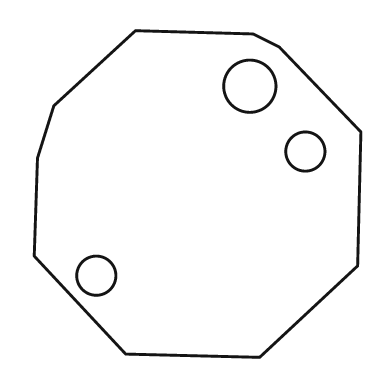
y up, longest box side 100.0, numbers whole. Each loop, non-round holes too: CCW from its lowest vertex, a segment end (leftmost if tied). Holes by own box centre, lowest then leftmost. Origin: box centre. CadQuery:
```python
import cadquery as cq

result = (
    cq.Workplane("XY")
    .moveTo(19.0, -50.0)
    .lineTo(49.0, -22.0)
    .lineTo(50.0, 19.0)
    .lineTo(25.0, 45.0)
    .lineTo(17.0, 49.0)
    .lineTo(-19.0, 50.0)
    .lineTo(-44.0, 27.0)
    .lineTo(-49.0, 11.0)
    .lineTo(-50.0, -19.0)
    .lineTo(-22.0, -49.0)
    .close()
    .moveTo(-31.0, -25.0)
    .circle(6.0)
    .moveTo(33.0, 13.0)
    .circle(6.0)
    .moveTo(16.0, 33.0)
    .circle(8.0)
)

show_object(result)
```